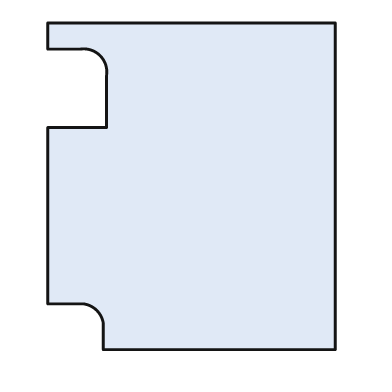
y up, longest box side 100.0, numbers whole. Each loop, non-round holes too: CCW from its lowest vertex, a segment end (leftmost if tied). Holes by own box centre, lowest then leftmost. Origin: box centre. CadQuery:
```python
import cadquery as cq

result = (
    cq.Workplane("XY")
    .moveTo(-27.0, -50.0)
    .lineTo(44.0, -50.0)
    .lineTo(44.0, 50.0)
    .lineTo(-44.0, 50.0)
    .lineTo(-44.0, 42.0)
    .lineTo(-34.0, 42.0)
    .threePointArc((-28.0, 40.0), (-26.0, 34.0))
    .lineTo(-26.0, 18.0)
    .lineTo(-44.0, 18.0)
    .lineTo(-44.0, -36.0)
    .lineTo(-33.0, -36.0)
    .threePointArc((-29.0, -38.0), (-27.0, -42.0))
    .close()
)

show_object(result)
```